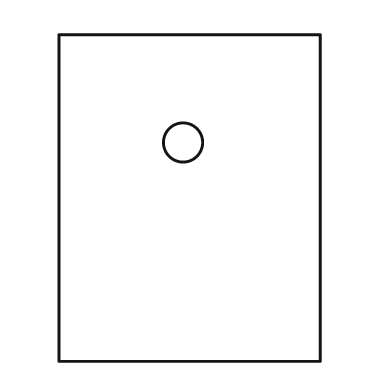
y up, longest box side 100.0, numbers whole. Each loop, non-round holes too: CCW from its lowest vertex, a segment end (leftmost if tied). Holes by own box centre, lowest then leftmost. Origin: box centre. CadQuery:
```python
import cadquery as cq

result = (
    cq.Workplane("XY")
    .moveTo(-40.0, -50.0)
    .lineTo(40.0, -50.0)
    .lineTo(40.0, 50.0)
    .lineTo(-40.0, 50.0)
    .close()
    .moveTo(-2.0, 17.0)
    .circle(6.0)
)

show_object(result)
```